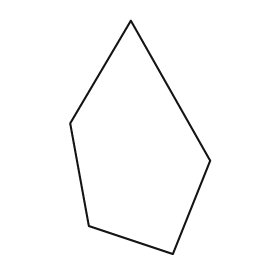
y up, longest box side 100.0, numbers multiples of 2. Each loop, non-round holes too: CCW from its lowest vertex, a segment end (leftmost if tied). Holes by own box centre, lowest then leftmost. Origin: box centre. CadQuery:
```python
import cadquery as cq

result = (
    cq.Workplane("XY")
    .moveTo(14.0, -50.0)
    .lineTo(30.0, -10.0)
    .lineTo(-4.0, 50.0)
    .lineTo(-30.0, 6.0)
    .lineTo(-22.0, -38.0)
    .close()
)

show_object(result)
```